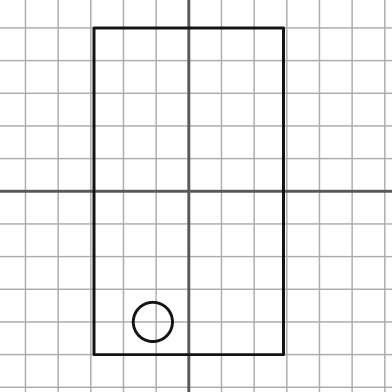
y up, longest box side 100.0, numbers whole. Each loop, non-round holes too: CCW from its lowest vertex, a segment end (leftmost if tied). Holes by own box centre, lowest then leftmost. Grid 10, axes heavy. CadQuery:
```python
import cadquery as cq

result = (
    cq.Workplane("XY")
    .moveTo(-29.0, -50.0)
    .lineTo(29.0, -50.0)
    .lineTo(29.0, 50.0)
    .lineTo(-29.0, 50.0)
    .close()
    .moveTo(-11.0, -40.0)
    .circle(6.0)
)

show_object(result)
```